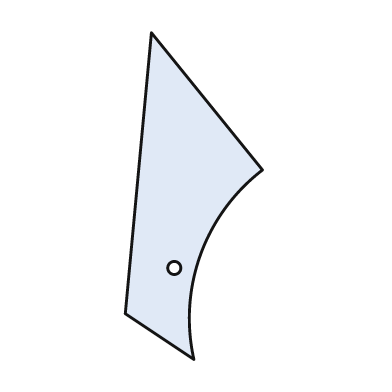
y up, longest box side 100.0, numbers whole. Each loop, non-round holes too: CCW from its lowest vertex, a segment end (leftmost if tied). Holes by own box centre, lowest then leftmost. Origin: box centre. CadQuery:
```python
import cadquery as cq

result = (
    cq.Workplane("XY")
    .moveTo(0.0, -50.0)
    .threePointArc((2.0, -18.0), (21.0, 8.0))
    .lineTo(-13.0, 50.0)
    .lineTo(-21.0, -36.0)
    .close()
    .moveTo(-6.0, -22.0)
    .circle(2.0)
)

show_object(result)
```